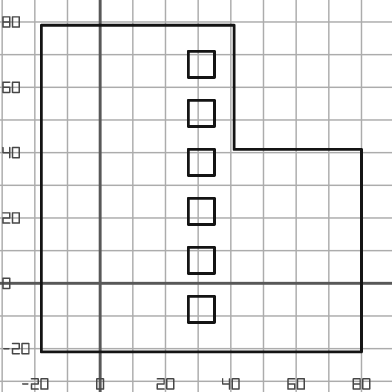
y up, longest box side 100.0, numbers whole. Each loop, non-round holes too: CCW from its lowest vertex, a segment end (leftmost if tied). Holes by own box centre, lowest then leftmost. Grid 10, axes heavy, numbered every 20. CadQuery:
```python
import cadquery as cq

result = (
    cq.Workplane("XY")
    .moveTo(-18.0, -21.0)
    .lineTo(80.0, -21.0)
    .lineTo(80.0, 41.0)
    .lineTo(41.0, 41.0)
    .lineTo(41.0, 79.0)
    .lineTo(-18.0, 79.0)
    .close()
    .moveTo(27.0, -12.0)
    .lineTo(35.0, -12.0)
    .lineTo(35.0, -4.0)
    .lineTo(27.0, -4.0)
    .close()
    .moveTo(27.0, 3.0)
    .lineTo(35.0, 3.0)
    .lineTo(35.0, 11.0)
    .lineTo(27.0, 11.0)
    .close()
    .moveTo(27.0, 18.0)
    .lineTo(35.0, 18.0)
    .lineTo(35.0, 26.0)
    .lineTo(27.0, 26.0)
    .close()
    .moveTo(27.0, 33.0)
    .lineTo(35.0, 33.0)
    .lineTo(35.0, 41.0)
    .lineTo(27.0, 41.0)
    .close()
    .moveTo(27.0, 48.0)
    .lineTo(35.0, 48.0)
    .lineTo(35.0, 56.0)
    .lineTo(27.0, 56.0)
    .close()
    .moveTo(27.0, 63.0)
    .lineTo(35.0, 63.0)
    .lineTo(35.0, 71.0)
    .lineTo(27.0, 71.0)
    .close()
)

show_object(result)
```